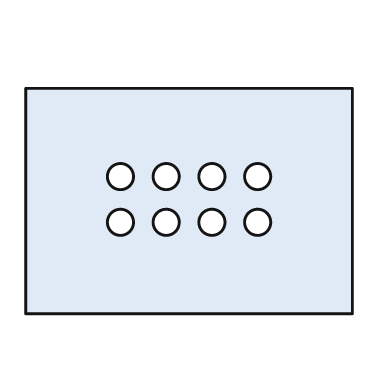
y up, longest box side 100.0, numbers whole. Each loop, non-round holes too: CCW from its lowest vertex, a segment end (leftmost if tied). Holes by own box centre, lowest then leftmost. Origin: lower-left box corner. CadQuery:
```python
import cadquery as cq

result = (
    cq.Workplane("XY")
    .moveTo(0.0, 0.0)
    .lineTo(100.0, 0.0)
    .lineTo(100.0, 69.0)
    .lineTo(0.0, 69.0)
    .close()
    .moveTo(29.0, 28.0)
    .circle(4.0)
    .moveTo(43.0, 28.0)
    .circle(4.0)
    .moveTo(57.0, 28.0)
    .circle(4.0)
    .moveTo(71.0, 28.0)
    .circle(4.0)
    .moveTo(29.0, 42.0)
    .circle(4.0)
    .moveTo(43.0, 42.0)
    .circle(4.0)
    .moveTo(57.0, 42.0)
    .circle(4.0)
    .moveTo(71.0, 42.0)
    .circle(4.0)
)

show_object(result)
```